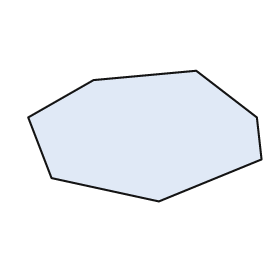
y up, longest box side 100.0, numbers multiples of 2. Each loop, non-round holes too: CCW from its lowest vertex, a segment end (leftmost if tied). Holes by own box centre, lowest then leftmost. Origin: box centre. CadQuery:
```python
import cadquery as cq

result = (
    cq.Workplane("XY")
    .moveTo(6.0, -28.0)
    .lineTo(50.0, -10.0)
    .lineTo(48.0, 8.0)
    .lineTo(22.0, 28.0)
    .lineTo(-22.0, 24.0)
    .lineTo(-50.0, 8.0)
    .lineTo(-40.0, -18.0)
    .close()
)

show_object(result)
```